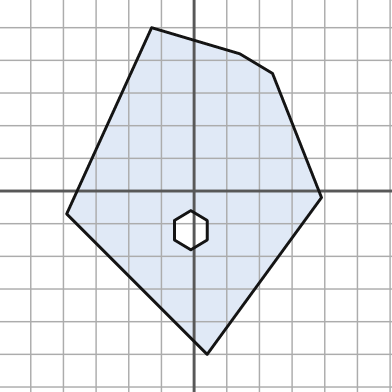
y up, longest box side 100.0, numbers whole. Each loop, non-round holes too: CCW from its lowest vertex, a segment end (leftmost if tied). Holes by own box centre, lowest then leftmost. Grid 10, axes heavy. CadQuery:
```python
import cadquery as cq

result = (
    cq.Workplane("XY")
    .moveTo(4.0, -50.0)
    .lineTo(39.0, -2.0)
    .lineTo(24.0, 36.0)
    .lineTo(14.0, 42.0)
    .lineTo(-13.0, 50.0)
    .lineTo(-39.0, -7.0)
    .close()
    .moveTo(-1.0, -18.0)
    .lineTo(4.0, -15.0)
    .lineTo(4.0, -9.0)
    .lineTo(-1.0, -6.0)
    .lineTo(-6.0, -9.0)
    .lineTo(-6.0, -15.0)
    .close()
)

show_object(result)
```